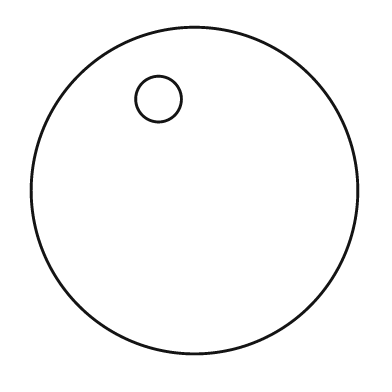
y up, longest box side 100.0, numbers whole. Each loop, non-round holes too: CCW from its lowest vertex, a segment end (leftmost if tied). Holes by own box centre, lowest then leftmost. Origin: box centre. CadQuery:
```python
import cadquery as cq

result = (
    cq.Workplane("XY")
    .moveTo(0.0, 0.0)
    .circle(50.0)
    .moveTo(-11.0, 28.0)
    .circle(7.0)
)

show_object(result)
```